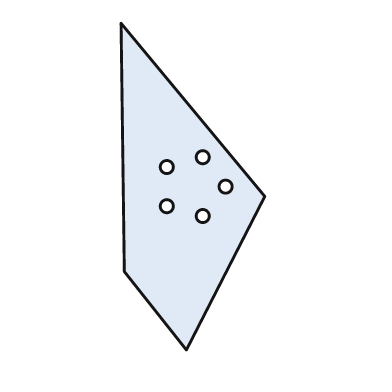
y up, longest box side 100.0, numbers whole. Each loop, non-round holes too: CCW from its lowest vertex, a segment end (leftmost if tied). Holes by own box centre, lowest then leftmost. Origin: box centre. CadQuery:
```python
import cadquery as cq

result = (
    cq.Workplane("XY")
    .moveTo(-2.0, -50.0)
    .lineTo(22.0, -3.0)
    .lineTo(-22.0, 50.0)
    .lineTo(-21.0, -26.0)
    .close()
    .moveTo(3.0, -9.0)
    .circle(2.0)
    .moveTo(-8.0, -6.0)
    .circle(2.0)
    .moveTo(10.0, 0.0)
    .circle(2.0)
    .moveTo(-8.0, 6.0)
    .circle(2.0)
    .moveTo(3.0, 9.0)
    .circle(2.0)
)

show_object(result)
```